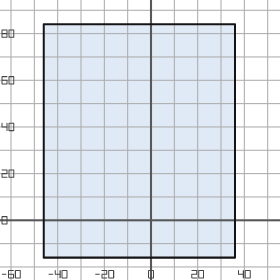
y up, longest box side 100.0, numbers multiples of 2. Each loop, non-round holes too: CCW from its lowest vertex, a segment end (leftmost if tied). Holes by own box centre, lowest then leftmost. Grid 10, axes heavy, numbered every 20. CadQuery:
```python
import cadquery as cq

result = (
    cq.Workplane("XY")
    .moveTo(-46.0, -16.0)
    .lineTo(36.0, -16.0)
    .lineTo(36.0, 84.0)
    .lineTo(-46.0, 84.0)
    .close()
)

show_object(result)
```